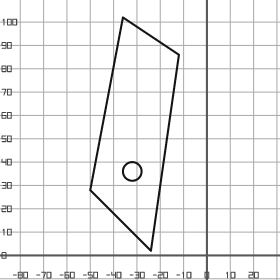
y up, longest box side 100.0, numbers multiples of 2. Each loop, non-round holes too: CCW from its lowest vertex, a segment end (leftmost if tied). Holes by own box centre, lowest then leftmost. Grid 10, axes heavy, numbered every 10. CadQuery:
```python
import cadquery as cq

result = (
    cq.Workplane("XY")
    .moveTo(-24.0, 2.0)
    .lineTo(-12.0, 86.0)
    .lineTo(-36.0, 102.0)
    .lineTo(-50.0, 28.0)
    .close()
    .moveTo(-32.0, 36.0)
    .circle(4.0)
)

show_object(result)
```